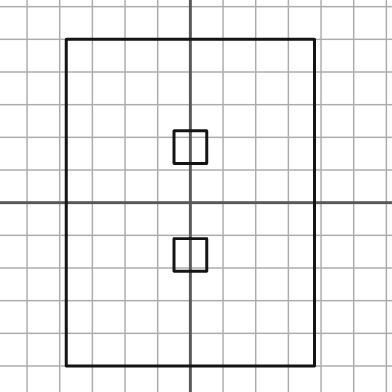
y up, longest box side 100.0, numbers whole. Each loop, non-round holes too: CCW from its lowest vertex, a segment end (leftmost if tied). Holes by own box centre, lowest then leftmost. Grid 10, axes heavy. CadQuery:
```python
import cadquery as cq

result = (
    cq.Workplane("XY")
    .moveTo(-38.0, -50.0)
    .lineTo(38.0, -50.0)
    .lineTo(38.0, 50.0)
    .lineTo(-38.0, 50.0)
    .close()
    .moveTo(-5.0, -21.0)
    .lineTo(5.0, -21.0)
    .lineTo(5.0, -11.0)
    .lineTo(-5.0, -11.0)
    .close()
    .moveTo(-5.0, 12.0)
    .lineTo(5.0, 12.0)
    .lineTo(5.0, 22.0)
    .lineTo(-5.0, 22.0)
    .close()
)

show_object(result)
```